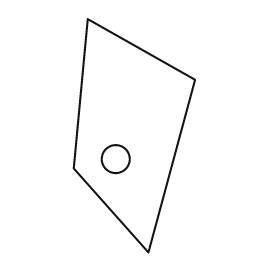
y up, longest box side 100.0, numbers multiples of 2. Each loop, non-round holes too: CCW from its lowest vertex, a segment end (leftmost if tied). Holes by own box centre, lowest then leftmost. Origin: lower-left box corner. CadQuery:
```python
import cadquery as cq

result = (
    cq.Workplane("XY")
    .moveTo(32.0, 0.0)
    .lineTo(52.0, 74.0)
    .lineTo(6.0, 100.0)
    .lineTo(0.0, 36.0)
    .close()
    .moveTo(18.0, 40.0)
    .circle(6.0)
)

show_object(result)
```